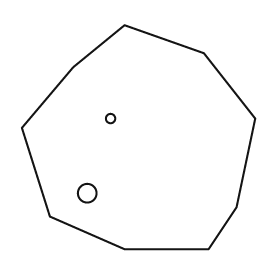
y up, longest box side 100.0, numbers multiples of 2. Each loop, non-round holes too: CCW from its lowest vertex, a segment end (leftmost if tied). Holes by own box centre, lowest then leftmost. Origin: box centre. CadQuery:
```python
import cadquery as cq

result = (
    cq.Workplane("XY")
    .moveTo(-6.0, -48.0)
    .lineTo(30.0, -48.0)
    .lineTo(42.0, -30.0)
    .lineTo(50.0, 8.0)
    .lineTo(28.0, 36.0)
    .lineTo(-6.0, 48.0)
    .lineTo(-28.0, 30.0)
    .lineTo(-50.0, 4.0)
    .lineTo(-38.0, -34.0)
    .close()
    .moveTo(-22.0, -24.0)
    .circle(4.0)
    .moveTo(-12.0, 8.0)
    .circle(2.0)
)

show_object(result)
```